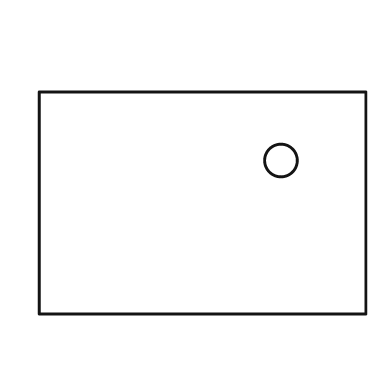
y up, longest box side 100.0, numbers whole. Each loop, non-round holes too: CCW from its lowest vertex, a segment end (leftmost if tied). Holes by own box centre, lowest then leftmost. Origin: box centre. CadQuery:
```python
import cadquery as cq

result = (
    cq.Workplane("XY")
    .moveTo(-50.0, -34.0)
    .lineTo(50.0, -34.0)
    .lineTo(50.0, 34.0)
    .lineTo(-50.0, 34.0)
    .close()
    .moveTo(24.0, 13.0)
    .circle(5.0)
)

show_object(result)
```